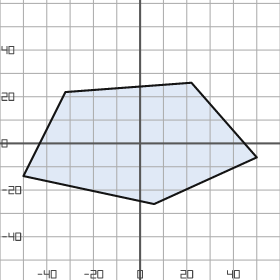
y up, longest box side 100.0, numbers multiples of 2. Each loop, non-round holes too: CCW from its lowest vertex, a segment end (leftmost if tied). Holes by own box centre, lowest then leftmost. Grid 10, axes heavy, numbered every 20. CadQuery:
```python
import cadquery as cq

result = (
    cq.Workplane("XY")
    .moveTo(6.0, -26.0)
    .lineTo(50.0, -6.0)
    .lineTo(22.0, 26.0)
    .lineTo(-32.0, 22.0)
    .lineTo(-50.0, -14.0)
    .close()
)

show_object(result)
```